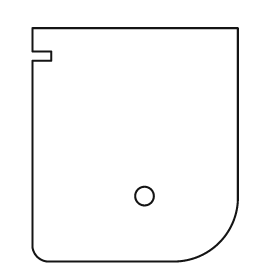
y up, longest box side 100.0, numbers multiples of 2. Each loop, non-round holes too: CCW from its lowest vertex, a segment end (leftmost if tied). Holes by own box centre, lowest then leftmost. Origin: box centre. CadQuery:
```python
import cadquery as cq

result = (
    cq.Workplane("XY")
    .moveTo(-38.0, -50.0)
    .lineTo(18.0, -50.0)
    .threePointArc((36.0, -42.0), (44.0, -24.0))
    .lineTo(44.0, 50.0)
    .lineTo(-44.0, 50.0)
    .lineTo(-44.0, 40.0)
    .lineTo(-36.0, 40.0)
    .lineTo(-36.0, 36.0)
    .lineTo(-44.0, 36.0)
    .lineTo(-44.0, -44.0)
    .threePointArc((-42.0, -48.0), (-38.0, -50.0))
    .close()
    .moveTo(4.0, -22.0)
    .circle(4.0)
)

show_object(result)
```